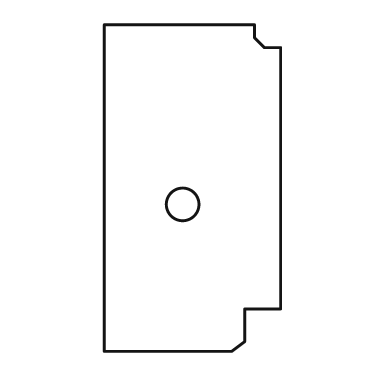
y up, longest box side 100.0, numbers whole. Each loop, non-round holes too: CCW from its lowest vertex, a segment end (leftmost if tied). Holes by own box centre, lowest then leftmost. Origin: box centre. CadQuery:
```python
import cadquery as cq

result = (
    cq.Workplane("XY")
    .moveTo(-27.0, -50.0)
    .lineTo(12.0, -50.0)
    .lineTo(16.0, -47.0)
    .lineTo(16.0, -37.0)
    .lineTo(27.0, -37.0)
    .lineTo(27.0, 43.0)
    .lineTo(22.0, 43.0)
    .lineTo(19.0, 46.0)
    .lineTo(19.0, 50.0)
    .lineTo(-27.0, 50.0)
    .close()
    .moveTo(-3.0, -5.0)
    .circle(5.0)
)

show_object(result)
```